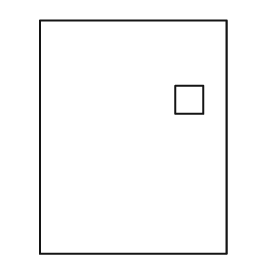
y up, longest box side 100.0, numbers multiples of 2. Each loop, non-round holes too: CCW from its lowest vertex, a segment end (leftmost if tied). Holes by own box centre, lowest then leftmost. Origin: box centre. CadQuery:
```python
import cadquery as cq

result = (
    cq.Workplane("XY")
    .moveTo(-40.0, -50.0)
    .lineTo(40.0, -50.0)
    .lineTo(40.0, 50.0)
    .lineTo(-40.0, 50.0)
    .close()
    .moveTo(18.0, 10.0)
    .lineTo(30.0, 10.0)
    .lineTo(30.0, 22.0)
    .lineTo(18.0, 22.0)
    .close()
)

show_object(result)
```